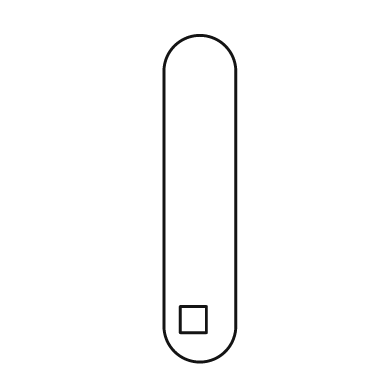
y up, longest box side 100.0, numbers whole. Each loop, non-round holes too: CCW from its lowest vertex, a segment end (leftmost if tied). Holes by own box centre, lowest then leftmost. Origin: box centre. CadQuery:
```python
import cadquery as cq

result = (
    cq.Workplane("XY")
    .moveTo(-11.0, -39.0)
    .threePointArc((0.0, -50.0), (11.0, -39.0))
    .lineTo(11.0, 39.0)
    .threePointArc((0.0, 50.0), (-11.0, 39.0))
    .close()
    .moveTo(-6.0, -41.0)
    .lineTo(2.0, -41.0)
    .lineTo(2.0, -33.0)
    .lineTo(-6.0, -33.0)
    .close()
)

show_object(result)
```